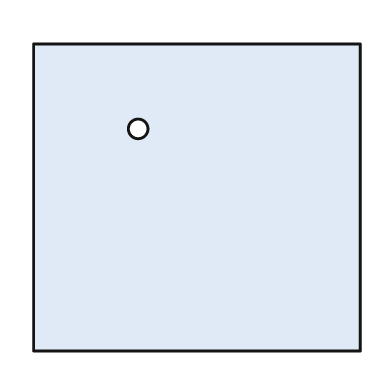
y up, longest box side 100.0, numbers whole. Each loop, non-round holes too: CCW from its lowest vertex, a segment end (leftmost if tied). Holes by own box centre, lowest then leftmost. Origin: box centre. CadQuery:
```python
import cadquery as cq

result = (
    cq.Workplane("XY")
    .moveTo(-50.0, -47.0)
    .lineTo(50.0, -47.0)
    .lineTo(50.0, 47.0)
    .lineTo(-50.0, 47.0)
    .close()
    .moveTo(-18.0, 21.0)
    .circle(3.0)
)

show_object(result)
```